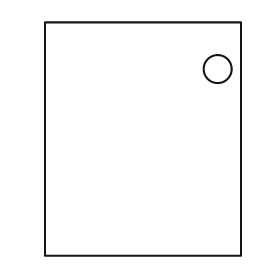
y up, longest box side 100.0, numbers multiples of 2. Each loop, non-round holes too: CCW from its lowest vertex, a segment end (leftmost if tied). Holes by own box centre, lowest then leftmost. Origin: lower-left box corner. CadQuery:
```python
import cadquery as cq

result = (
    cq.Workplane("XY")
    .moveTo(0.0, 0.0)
    .lineTo(84.0, 0.0)
    .lineTo(84.0, 100.0)
    .lineTo(0.0, 100.0)
    .close()
    .moveTo(74.0, 80.0)
    .circle(6.0)
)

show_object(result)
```